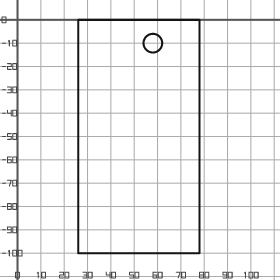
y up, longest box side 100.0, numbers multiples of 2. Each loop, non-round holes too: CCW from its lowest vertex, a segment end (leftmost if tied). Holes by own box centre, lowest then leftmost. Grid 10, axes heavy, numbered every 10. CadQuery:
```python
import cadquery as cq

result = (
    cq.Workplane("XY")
    .moveTo(26.0, -100.0)
    .lineTo(78.0, -100.0)
    .lineTo(78.0, 0.0)
    .lineTo(26.0, 0.0)
    .close()
    .moveTo(58.0, -10.0)
    .circle(4.0)
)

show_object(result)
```